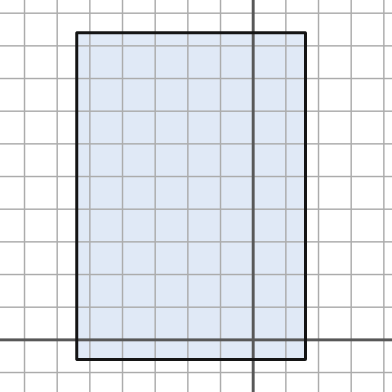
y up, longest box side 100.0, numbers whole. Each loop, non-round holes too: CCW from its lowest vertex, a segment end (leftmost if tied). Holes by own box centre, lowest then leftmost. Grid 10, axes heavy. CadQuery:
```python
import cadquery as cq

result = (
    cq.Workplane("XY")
    .moveTo(-54.0, -6.0)
    .lineTo(16.0, -6.0)
    .lineTo(16.0, 94.0)
    .lineTo(-54.0, 94.0)
    .close()
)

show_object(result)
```